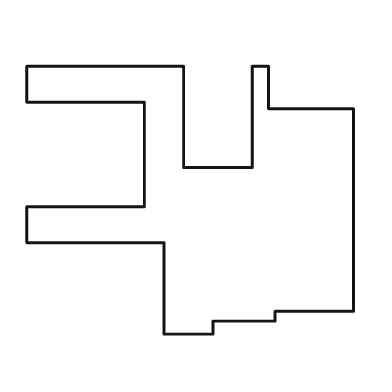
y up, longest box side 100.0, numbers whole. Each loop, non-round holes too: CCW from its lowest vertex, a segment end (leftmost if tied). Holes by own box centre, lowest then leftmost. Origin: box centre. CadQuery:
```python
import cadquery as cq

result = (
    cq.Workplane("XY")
    .moveTo(-8.0, -41.0)
    .lineTo(7.0, -41.0)
    .lineTo(7.0, -37.0)
    .lineTo(26.0, -37.0)
    .lineTo(26.0, -34.0)
    .lineTo(50.0, -34.0)
    .lineTo(50.0, 28.0)
    .lineTo(24.0, 28.0)
    .lineTo(24.0, 41.0)
    .lineTo(19.0, 41.0)
    .lineTo(19.0, 10.0)
    .lineTo(-2.0, 10.0)
    .lineTo(-2.0, 41.0)
    .lineTo(-50.0, 41.0)
    .lineTo(-50.0, 30.0)
    .lineTo(-14.0, 30.0)
    .lineTo(-14.0, -2.0)
    .lineTo(-50.0, -2.0)
    .lineTo(-50.0, -13.0)
    .lineTo(-8.0, -13.0)
    .close()
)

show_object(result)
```